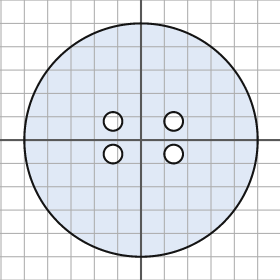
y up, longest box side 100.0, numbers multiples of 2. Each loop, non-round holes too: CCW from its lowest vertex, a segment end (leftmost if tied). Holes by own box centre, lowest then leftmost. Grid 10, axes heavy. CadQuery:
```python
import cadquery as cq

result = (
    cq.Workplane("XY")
    .moveTo(0.0, 0.0)
    .circle(50.0)
    .moveTo(-12.0, -6.0)
    .circle(4.0)
    .moveTo(14.0, -6.0)
    .circle(4.0)
    .moveTo(-12.0, 8.0)
    .circle(4.0)
    .moveTo(14.0, 8.0)
    .circle(4.0)
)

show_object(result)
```